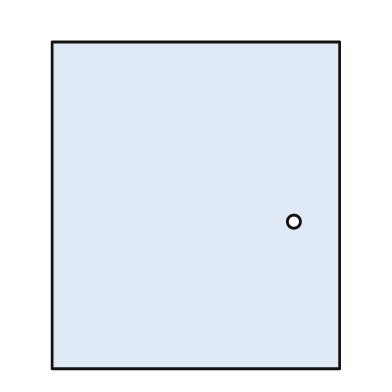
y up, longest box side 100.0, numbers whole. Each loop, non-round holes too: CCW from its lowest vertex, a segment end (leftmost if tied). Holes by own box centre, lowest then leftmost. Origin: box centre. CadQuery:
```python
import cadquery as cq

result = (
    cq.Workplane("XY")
    .moveTo(-44.0, -50.0)
    .lineTo(44.0, -50.0)
    .lineTo(44.0, 50.0)
    .lineTo(-44.0, 50.0)
    .close()
    .moveTo(30.0, -5.0)
    .circle(2.0)
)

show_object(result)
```